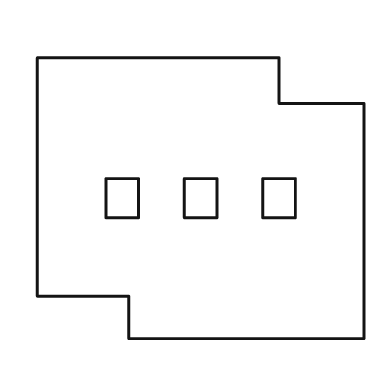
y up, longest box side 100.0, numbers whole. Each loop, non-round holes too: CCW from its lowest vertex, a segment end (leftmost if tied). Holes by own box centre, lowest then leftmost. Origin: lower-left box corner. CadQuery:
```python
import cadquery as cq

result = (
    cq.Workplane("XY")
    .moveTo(28.0, 0.0)
    .lineTo(100.0, 0.0)
    .lineTo(100.0, 72.0)
    .lineTo(74.0, 72.0)
    .lineTo(74.0, 86.0)
    .lineTo(0.0, 86.0)
    .lineTo(0.0, 13.0)
    .lineTo(28.0, 13.0)
    .close()
    .moveTo(21.0, 37.0)
    .lineTo(31.0, 37.0)
    .lineTo(31.0, 49.0)
    .lineTo(21.0, 49.0)
    .close()
    .moveTo(45.0, 37.0)
    .lineTo(55.0, 37.0)
    .lineTo(55.0, 49.0)
    .lineTo(45.0, 49.0)
    .close()
    .moveTo(69.0, 37.0)
    .lineTo(79.0, 37.0)
    .lineTo(79.0, 49.0)
    .lineTo(69.0, 49.0)
    .close()
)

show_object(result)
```